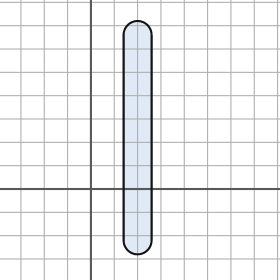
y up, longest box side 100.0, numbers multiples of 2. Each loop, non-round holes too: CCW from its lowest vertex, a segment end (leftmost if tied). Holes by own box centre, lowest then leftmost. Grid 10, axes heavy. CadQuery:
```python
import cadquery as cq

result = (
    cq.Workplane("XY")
    .moveTo(14.0, -22.0)
    .threePointArc((20.0, -28.0), (26.0, -22.0))
    .lineTo(26.0, 66.0)
    .threePointArc((20.0, 72.0), (14.0, 66.0))
    .close()
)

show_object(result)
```